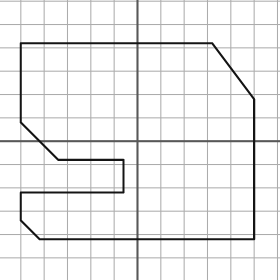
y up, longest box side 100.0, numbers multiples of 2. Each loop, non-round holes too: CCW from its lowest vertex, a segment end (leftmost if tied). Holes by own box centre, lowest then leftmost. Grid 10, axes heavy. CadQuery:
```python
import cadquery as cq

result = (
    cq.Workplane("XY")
    .moveTo(-42.0, -42.0)
    .lineTo(50.0, -42.0)
    .lineTo(50.0, 18.0)
    .lineTo(32.0, 42.0)
    .lineTo(-50.0, 42.0)
    .lineTo(-50.0, 8.0)
    .lineTo(-34.0, -8.0)
    .lineTo(-6.0, -8.0)
    .lineTo(-6.0, -22.0)
    .lineTo(-50.0, -22.0)
    .lineTo(-50.0, -34.0)
    .close()
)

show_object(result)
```